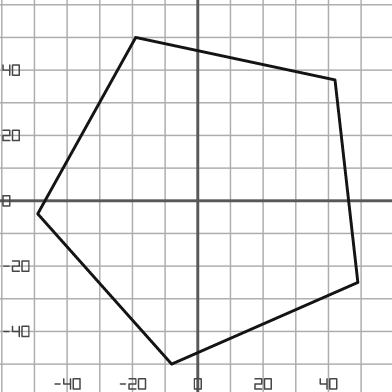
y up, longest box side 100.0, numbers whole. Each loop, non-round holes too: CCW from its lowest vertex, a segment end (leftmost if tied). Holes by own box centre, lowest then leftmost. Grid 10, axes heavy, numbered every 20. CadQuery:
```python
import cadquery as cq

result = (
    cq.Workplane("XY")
    .moveTo(-8.0, -50.0)
    .lineTo(49.0, -25.0)
    .lineTo(42.0, 37.0)
    .lineTo(-19.0, 50.0)
    .lineTo(-49.0, -4.0)
    .close()
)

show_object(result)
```